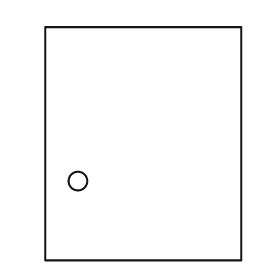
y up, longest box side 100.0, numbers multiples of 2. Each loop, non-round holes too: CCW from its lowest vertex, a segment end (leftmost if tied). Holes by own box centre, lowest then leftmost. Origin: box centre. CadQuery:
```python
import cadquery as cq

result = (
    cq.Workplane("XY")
    .moveTo(-42.0, -50.0)
    .lineTo(42.0, -50.0)
    .lineTo(42.0, 50.0)
    .lineTo(-42.0, 50.0)
    .close()
    .moveTo(-28.0, -16.0)
    .circle(4.0)
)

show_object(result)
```